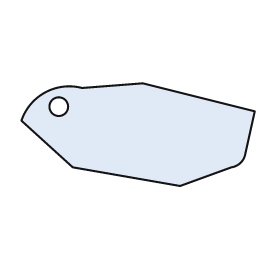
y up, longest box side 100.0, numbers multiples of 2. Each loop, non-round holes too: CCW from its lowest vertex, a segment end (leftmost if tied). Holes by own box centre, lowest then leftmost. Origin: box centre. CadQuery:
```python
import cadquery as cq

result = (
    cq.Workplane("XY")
    .moveTo(18.0, -22.0)
    .lineTo(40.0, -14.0)
    .threePointArc((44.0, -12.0), (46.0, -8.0))
    .lineTo(50.0, 10.0)
    .lineTo(2.0, 22.0)
    .lineTo(-24.0, 20.0)
    .threePointArc((-40.0, 18.0), (-50.0, 6.0))
    .lineTo(-28.0, -14.0)
    .close()
    .moveTo(-34.0, 12.0)
    .circle(4.0)
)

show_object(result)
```